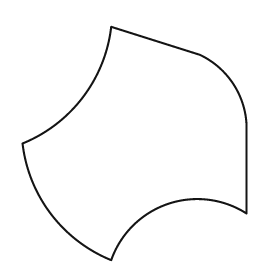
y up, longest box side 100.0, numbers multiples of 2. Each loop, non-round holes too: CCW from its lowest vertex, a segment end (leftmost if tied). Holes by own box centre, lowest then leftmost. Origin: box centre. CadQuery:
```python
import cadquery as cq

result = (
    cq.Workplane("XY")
    .moveTo(-10.0, -50.0)
    .threePointArc((14.0, -26.0), (48.0, -30.0))
    .lineTo(48.0, 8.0)
    .threePointArc((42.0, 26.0), (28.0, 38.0))
    .lineTo(-10.0, 50.0)
    .threePointArc((-22.0, 20.0), (-48.0, 0.0))
    .threePointArc((-36.0, -30.0), (-10.0, -50.0))
    .close()
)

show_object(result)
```